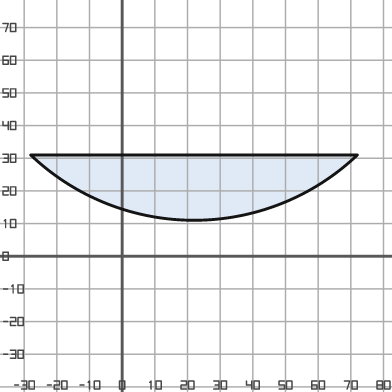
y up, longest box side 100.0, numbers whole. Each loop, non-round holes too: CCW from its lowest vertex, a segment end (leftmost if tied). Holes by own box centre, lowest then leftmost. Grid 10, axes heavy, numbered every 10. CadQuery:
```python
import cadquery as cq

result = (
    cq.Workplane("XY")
    .moveTo(-28.0, 31.0)
    .threePointArc((22.0, 11.0), (72.0, 31.0))
    .close()
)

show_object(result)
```